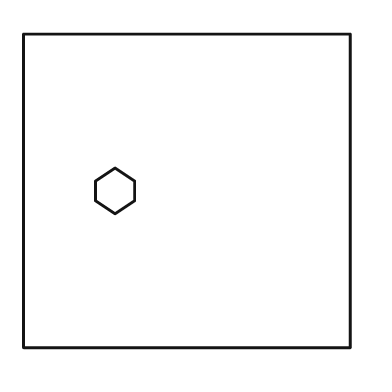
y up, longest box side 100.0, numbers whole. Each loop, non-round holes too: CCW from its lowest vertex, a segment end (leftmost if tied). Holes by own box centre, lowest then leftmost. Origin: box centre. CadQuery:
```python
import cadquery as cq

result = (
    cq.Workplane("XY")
    .moveTo(-50.0, -48.0)
    .lineTo(50.0, -48.0)
    .lineTo(50.0, 48.0)
    .lineTo(-50.0, 48.0)
    .close()
    .moveTo(-22.0, -7.0)
    .lineTo(-16.0, -3.0)
    .lineTo(-16.0, 3.0)
    .lineTo(-22.0, 7.0)
    .lineTo(-28.0, 3.0)
    .lineTo(-28.0, -3.0)
    .close()
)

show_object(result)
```